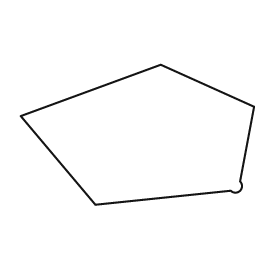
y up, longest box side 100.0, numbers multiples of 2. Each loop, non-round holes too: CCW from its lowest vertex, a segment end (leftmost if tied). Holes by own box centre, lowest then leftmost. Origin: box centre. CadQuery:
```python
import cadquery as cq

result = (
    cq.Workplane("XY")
    .moveTo(-18.0, -30.0)
    .lineTo(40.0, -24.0)
    .threePointArc((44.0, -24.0), (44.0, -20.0))
    .lineTo(50.0, 12.0)
    .lineTo(10.0, 30.0)
    .lineTo(-50.0, 8.0)
    .close()
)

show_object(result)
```